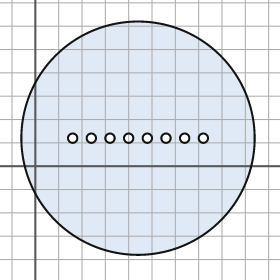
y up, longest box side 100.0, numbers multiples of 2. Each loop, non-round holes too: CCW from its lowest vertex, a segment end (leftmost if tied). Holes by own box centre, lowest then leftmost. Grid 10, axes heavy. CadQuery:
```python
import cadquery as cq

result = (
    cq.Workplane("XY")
    .moveTo(44.0, 12.0)
    .circle(50.0)
    .moveTo(16.0, 12.0)
    .circle(2.0)
    .moveTo(24.0, 12.0)
    .circle(2.0)
    .moveTo(32.0, 12.0)
    .circle(2.0)
    .moveTo(40.0, 12.0)
    .circle(2.0)
    .moveTo(48.0, 12.0)
    .circle(2.0)
    .moveTo(56.0, 12.0)
    .circle(2.0)
    .moveTo(64.0, 12.0)
    .circle(2.0)
    .moveTo(72.0, 12.0)
    .circle(2.0)
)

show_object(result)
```